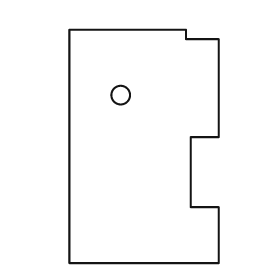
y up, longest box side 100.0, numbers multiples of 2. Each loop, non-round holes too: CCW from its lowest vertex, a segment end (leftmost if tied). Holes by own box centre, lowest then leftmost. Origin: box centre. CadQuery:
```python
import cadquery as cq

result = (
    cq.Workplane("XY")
    .moveTo(-32.0, -50.0)
    .lineTo(32.0, -50.0)
    .lineTo(32.0, -26.0)
    .lineTo(20.0, -26.0)
    .lineTo(20.0, 4.0)
    .lineTo(32.0, 4.0)
    .lineTo(32.0, 46.0)
    .lineTo(18.0, 46.0)
    .lineTo(18.0, 50.0)
    .lineTo(-32.0, 50.0)
    .close()
    .moveTo(-10.0, 22.0)
    .circle(4.0)
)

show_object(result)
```